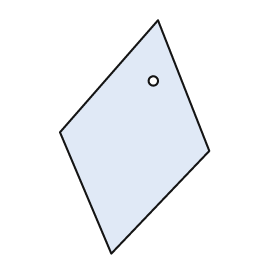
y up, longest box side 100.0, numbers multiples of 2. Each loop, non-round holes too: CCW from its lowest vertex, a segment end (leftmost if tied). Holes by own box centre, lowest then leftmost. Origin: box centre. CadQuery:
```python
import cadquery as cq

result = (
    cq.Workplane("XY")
    .moveTo(-10.0, -50.0)
    .lineTo(32.0, -6.0)
    .lineTo(10.0, 50.0)
    .lineTo(-32.0, 2.0)
    .close()
    .moveTo(8.0, 24.0)
    .circle(2.0)
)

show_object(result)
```